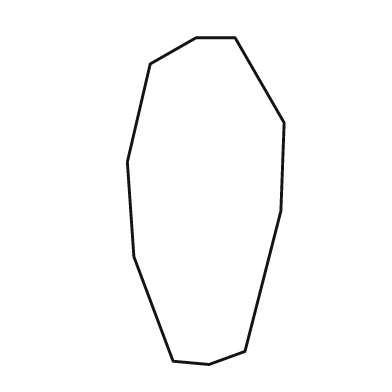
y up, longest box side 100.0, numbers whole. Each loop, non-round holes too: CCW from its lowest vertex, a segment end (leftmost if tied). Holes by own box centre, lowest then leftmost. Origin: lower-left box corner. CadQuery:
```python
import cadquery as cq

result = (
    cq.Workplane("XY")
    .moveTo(25.0, 0.0)
    .lineTo(36.0, 4.0)
    .lineTo(47.0, 47.0)
    .lineTo(48.0, 74.0)
    .lineTo(33.0, 100.0)
    .lineTo(21.0, 100.0)
    .lineTo(7.0, 92.0)
    .lineTo(0.0, 62.0)
    .lineTo(2.0, 33.0)
    .lineTo(14.0, 1.0)
    .close()
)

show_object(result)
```